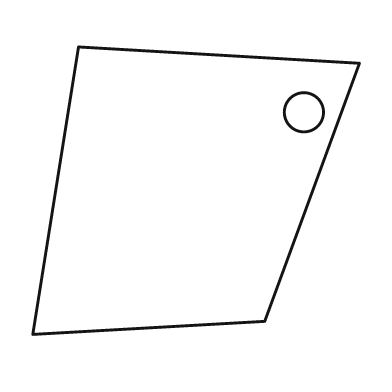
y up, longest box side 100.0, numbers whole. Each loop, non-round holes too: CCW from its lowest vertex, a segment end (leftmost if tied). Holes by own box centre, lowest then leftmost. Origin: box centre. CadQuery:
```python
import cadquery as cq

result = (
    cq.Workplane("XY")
    .moveTo(-50.0, -44.0)
    .lineTo(21.0, -40.0)
    .lineTo(50.0, 39.0)
    .lineTo(-36.0, 44.0)
    .close()
    .moveTo(33.0, 24.0)
    .circle(6.0)
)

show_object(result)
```